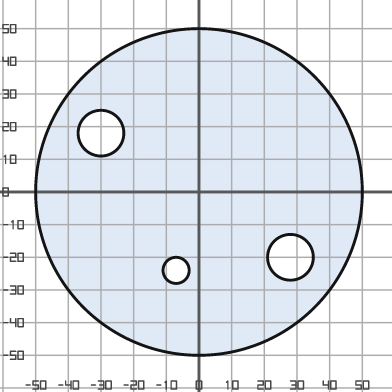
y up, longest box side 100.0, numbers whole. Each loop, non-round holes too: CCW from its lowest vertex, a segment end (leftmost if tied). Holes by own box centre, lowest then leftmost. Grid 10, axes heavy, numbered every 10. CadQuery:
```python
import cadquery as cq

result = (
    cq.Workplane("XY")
    .moveTo(0.0, 0.0)
    .circle(50.0)
    .moveTo(-7.0, -24.0)
    .circle(4.0)
    .moveTo(28.0, -20.0)
    .circle(7.0)
    .moveTo(-30.0, 18.0)
    .circle(7.0)
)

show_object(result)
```